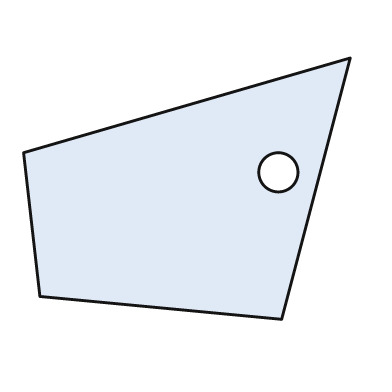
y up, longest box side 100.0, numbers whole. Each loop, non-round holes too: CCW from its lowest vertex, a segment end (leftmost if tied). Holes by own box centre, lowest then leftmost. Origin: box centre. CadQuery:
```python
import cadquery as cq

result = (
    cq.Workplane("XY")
    .moveTo(29.0, -40.0)
    .lineTo(50.0, 40.0)
    .lineTo(-50.0, 11.0)
    .lineTo(-45.0, -33.0)
    .close()
    .moveTo(28.0, 5.0)
    .circle(6.0)
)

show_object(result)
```